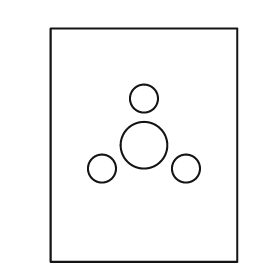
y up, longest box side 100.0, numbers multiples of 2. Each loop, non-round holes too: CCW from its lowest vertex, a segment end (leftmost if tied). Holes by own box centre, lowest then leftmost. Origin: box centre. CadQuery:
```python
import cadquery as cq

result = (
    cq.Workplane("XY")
    .moveTo(-40.0, -50.0)
    .lineTo(40.0, -50.0)
    .lineTo(40.0, 50.0)
    .lineTo(-40.0, 50.0)
    .close()
    .moveTo(-18.0, -10.0)
    .circle(6.0)
    .moveTo(18.0, -10.0)
    .circle(6.0)
    .moveTo(0.0, 0.0)
    .circle(10.0)
    .moveTo(0.0, 20.0)
    .circle(6.0)
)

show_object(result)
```